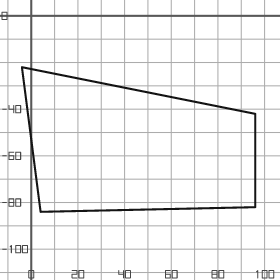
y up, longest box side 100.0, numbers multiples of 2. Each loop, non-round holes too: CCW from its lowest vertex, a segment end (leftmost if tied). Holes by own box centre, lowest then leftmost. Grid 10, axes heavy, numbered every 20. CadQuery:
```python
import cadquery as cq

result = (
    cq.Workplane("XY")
    .moveTo(4.0, -84.0)
    .lineTo(96.0, -82.0)
    .lineTo(96.0, -42.0)
    .lineTo(-4.0, -22.0)
    .close()
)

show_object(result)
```